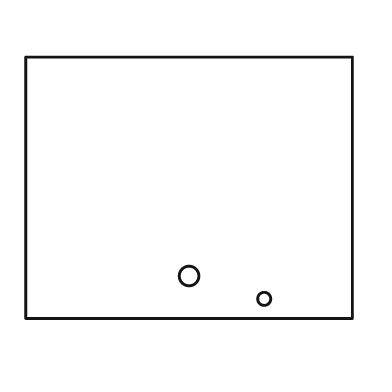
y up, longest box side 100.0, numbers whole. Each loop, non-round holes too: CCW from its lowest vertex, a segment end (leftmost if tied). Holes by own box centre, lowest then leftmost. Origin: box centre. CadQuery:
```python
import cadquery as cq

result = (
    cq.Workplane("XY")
    .moveTo(-50.0, -40.0)
    .lineTo(50.0, -40.0)
    .lineTo(50.0, 40.0)
    .lineTo(-50.0, 40.0)
    .close()
    .moveTo(23.0, -34.0)
    .circle(2.0)
    .moveTo(0.0, -27.0)
    .circle(3.0)
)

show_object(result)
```